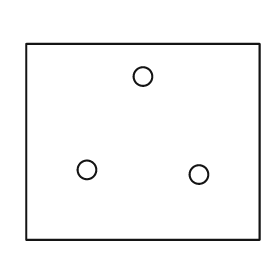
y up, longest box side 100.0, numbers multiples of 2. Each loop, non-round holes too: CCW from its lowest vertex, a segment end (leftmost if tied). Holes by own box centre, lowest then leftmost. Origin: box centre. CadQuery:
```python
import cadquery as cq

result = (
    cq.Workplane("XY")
    .moveTo(-50.0, -42.0)
    .lineTo(50.0, -42.0)
    .lineTo(50.0, 42.0)
    .lineTo(-50.0, 42.0)
    .close()
    .moveTo(24.0, -14.0)
    .circle(4.0)
    .moveTo(-24.0, -12.0)
    .circle(4.0)
    .moveTo(0.0, 28.0)
    .circle(4.0)
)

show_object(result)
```